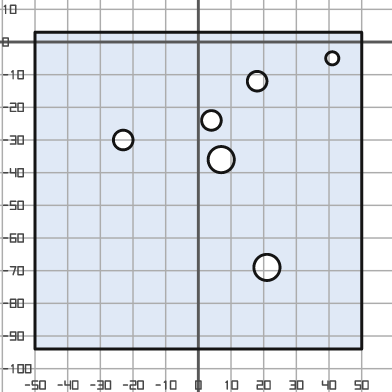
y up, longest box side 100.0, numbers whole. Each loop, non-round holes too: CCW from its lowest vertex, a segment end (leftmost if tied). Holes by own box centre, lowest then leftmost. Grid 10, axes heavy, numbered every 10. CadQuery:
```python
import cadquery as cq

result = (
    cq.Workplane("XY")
    .moveTo(-50.0, -94.0)
    .lineTo(50.0, -94.0)
    .lineTo(50.0, 3.0)
    .lineTo(-50.0, 3.0)
    .close()
    .moveTo(21.0, -69.0)
    .circle(4.0)
    .moveTo(7.0, -36.0)
    .circle(4.0)
    .moveTo(-23.0, -30.0)
    .circle(3.0)
    .moveTo(4.0, -24.0)
    .circle(3.0)
    .moveTo(18.0, -12.0)
    .circle(3.0)
    .moveTo(41.0, -5.0)
    .circle(2.0)
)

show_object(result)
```